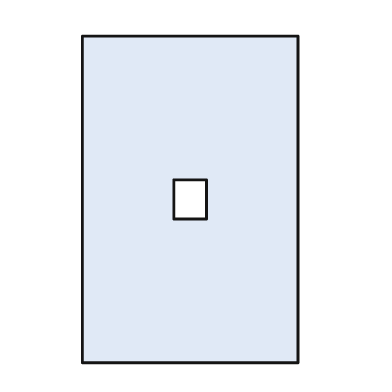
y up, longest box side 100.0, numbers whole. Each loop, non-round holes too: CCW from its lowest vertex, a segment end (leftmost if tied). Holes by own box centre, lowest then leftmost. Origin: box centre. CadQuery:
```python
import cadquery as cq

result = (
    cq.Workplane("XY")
    .moveTo(-33.0, -50.0)
    .lineTo(33.0, -50.0)
    .lineTo(33.0, 50.0)
    .lineTo(-33.0, 50.0)
    .close()
    .moveTo(-5.0, -6.0)
    .lineTo(5.0, -6.0)
    .lineTo(5.0, 6.0)
    .lineTo(-5.0, 6.0)
    .close()
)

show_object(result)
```